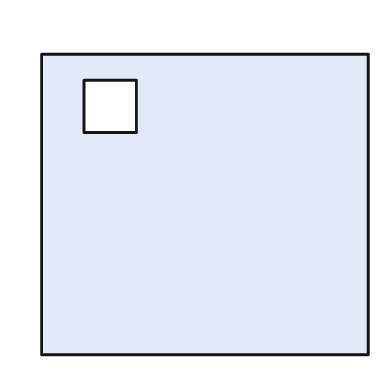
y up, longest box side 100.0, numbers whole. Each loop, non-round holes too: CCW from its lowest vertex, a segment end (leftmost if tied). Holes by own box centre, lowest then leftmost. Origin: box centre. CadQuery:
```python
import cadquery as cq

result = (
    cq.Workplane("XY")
    .moveTo(-50.0, -46.0)
    .lineTo(50.0, -46.0)
    .lineTo(50.0, 46.0)
    .lineTo(-50.0, 46.0)
    .close()
    .moveTo(-37.0, 22.0)
    .lineTo(-21.0, 22.0)
    .lineTo(-21.0, 38.0)
    .lineTo(-37.0, 38.0)
    .close()
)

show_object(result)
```